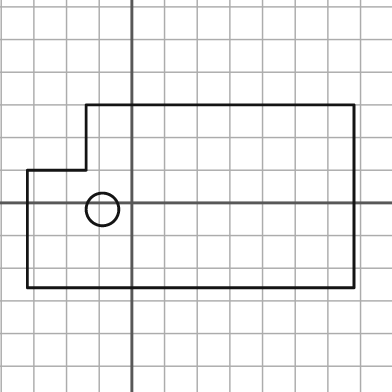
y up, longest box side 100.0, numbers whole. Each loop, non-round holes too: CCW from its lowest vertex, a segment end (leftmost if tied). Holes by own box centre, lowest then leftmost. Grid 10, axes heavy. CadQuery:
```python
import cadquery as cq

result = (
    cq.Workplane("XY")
    .moveTo(-32.0, -26.0)
    .lineTo(68.0, -26.0)
    .lineTo(68.0, 30.0)
    .lineTo(-14.0, 30.0)
    .lineTo(-14.0, 10.0)
    .lineTo(-32.0, 10.0)
    .close()
    .moveTo(-9.0, -2.0)
    .circle(5.0)
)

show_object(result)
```